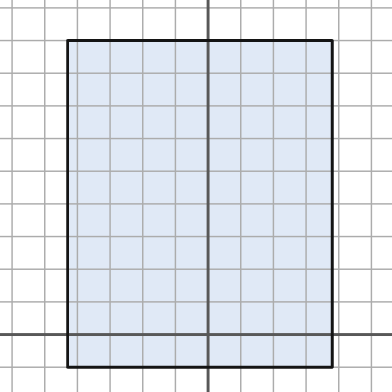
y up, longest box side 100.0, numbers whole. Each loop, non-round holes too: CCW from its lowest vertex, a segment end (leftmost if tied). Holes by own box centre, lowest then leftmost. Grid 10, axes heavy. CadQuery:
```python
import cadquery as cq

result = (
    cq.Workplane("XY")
    .moveTo(-43.0, -10.0)
    .lineTo(38.0, -10.0)
    .lineTo(38.0, 90.0)
    .lineTo(-43.0, 90.0)
    .close()
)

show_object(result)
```